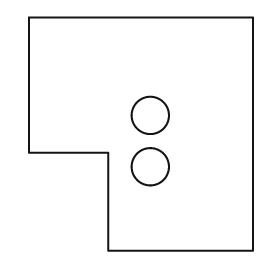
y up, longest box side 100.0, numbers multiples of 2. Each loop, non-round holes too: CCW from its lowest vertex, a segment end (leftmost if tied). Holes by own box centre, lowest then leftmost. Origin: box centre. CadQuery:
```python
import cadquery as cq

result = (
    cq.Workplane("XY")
    .moveTo(-14.0, -50.0)
    .lineTo(48.0, -50.0)
    .lineTo(48.0, 50.0)
    .lineTo(-48.0, 50.0)
    .lineTo(-48.0, -8.0)
    .lineTo(-14.0, -8.0)
    .close()
    .moveTo(4.0, -14.0)
    .circle(8.0)
    .moveTo(4.0, 8.0)
    .circle(8.0)
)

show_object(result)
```